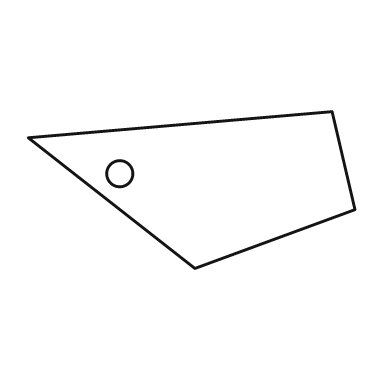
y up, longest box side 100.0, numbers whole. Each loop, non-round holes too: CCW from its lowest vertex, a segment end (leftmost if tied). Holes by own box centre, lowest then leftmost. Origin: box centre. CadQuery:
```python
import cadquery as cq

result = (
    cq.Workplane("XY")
    .moveTo(1.0, -24.0)
    .lineTo(50.0, -6.0)
    .lineTo(43.0, 24.0)
    .lineTo(-50.0, 16.0)
    .close()
    .moveTo(-22.0, 5.0)
    .circle(4.0)
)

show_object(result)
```